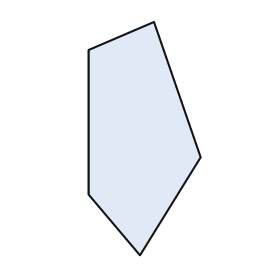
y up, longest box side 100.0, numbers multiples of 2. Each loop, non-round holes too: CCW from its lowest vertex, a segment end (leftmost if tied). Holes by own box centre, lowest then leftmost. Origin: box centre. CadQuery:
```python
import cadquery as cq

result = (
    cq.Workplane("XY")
    .moveTo(-2.0, -50.0)
    .lineTo(24.0, -8.0)
    .lineTo(4.0, 50.0)
    .lineTo(-24.0, 38.0)
    .lineTo(-24.0, -24.0)
    .close()
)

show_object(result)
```